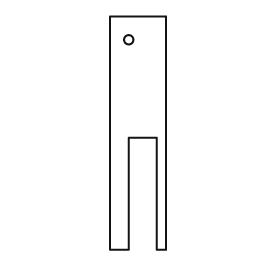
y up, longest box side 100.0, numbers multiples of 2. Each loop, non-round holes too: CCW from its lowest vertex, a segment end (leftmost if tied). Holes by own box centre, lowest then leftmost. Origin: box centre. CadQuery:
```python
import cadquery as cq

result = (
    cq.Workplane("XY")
    .moveTo(-12.0, -50.0)
    .lineTo(-4.0, -50.0)
    .lineTo(-4.0, -2.0)
    .lineTo(8.0, -2.0)
    .lineTo(8.0, -50.0)
    .lineTo(12.0, -50.0)
    .lineTo(12.0, 50.0)
    .lineTo(-12.0, 50.0)
    .close()
    .moveTo(-4.0, 40.0)
    .circle(2.0)
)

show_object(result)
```